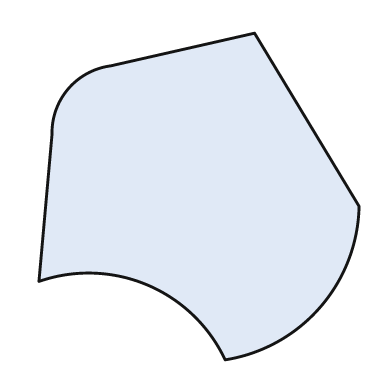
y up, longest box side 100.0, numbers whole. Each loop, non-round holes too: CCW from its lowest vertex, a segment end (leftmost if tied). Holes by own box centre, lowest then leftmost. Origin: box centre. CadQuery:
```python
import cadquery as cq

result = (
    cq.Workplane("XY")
    .moveTo(8.0, -50.0)
    .threePointArc((37.0, -34.0), (49.0, -3.0))
    .lineTo(17.0, 50.0)
    .lineTo(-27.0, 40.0)
    .threePointArc((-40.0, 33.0), (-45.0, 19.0))
    .lineTo(-49.0, -26.0)
    .threePointArc((-16.0, -27.0), (8.0, -50.0))
    .close()
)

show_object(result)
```